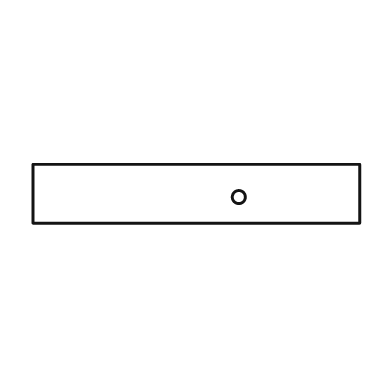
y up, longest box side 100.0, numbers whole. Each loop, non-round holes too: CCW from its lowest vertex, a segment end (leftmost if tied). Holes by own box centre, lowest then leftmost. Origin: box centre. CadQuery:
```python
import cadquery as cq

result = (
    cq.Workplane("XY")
    .moveTo(-50.0, -9.0)
    .lineTo(50.0, -9.0)
    .lineTo(50.0, 9.0)
    .lineTo(-50.0, 9.0)
    .close()
    .moveTo(13.0, -1.0)
    .circle(2.0)
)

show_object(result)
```